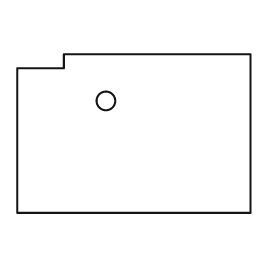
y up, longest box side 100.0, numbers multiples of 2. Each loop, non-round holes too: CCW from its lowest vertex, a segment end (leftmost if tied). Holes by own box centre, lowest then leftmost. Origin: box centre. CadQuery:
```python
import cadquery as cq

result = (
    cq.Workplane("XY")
    .moveTo(-50.0, -34.0)
    .lineTo(50.0, -34.0)
    .lineTo(50.0, 34.0)
    .lineTo(-30.0, 34.0)
    .lineTo(-30.0, 28.0)
    .lineTo(-50.0, 28.0)
    .close()
    .moveTo(-12.0, 14.0)
    .circle(4.0)
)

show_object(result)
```